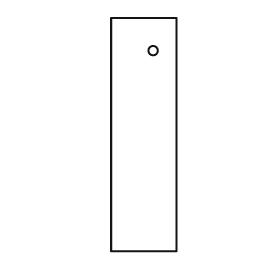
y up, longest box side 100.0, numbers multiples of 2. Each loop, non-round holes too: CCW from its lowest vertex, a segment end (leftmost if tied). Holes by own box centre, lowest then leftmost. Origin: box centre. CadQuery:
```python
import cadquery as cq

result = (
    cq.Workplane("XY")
    .moveTo(-14.0, -50.0)
    .lineTo(14.0, -50.0)
    .lineTo(14.0, 50.0)
    .lineTo(-14.0, 50.0)
    .close()
    .moveTo(4.0, 36.0)
    .circle(2.0)
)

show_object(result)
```